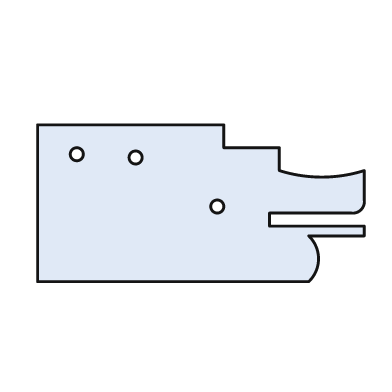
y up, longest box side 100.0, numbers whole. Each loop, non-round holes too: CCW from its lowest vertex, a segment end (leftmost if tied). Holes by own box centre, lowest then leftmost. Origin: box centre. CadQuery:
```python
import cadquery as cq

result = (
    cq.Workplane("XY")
    .moveTo(-50.0, -24.0)
    .lineTo(33.0, -24.0)
    .threePointArc((36.0, -17.0), (33.0, -10.0))
    .lineTo(50.0, -10.0)
    .lineTo(50.0, -7.0)
    .lineTo(21.0, -7.0)
    .lineTo(21.0, -3.0)
    .lineTo(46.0, -3.0)
    .threePointArc((49.0, -2.0), (50.0, 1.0))
    .lineTo(50.0, 10.0)
    .threePointArc((37.0, 8.0), (24.0, 10.0))
    .lineTo(24.0, 17.0)
    .lineTo(7.0, 17.0)
    .lineTo(7.0, 24.0)
    .lineTo(-50.0, 24.0)
    .close()
    .moveTo(5.0, -1.0)
    .circle(2.0)
    .moveTo(-20.0, 14.0)
    .circle(2.0)
    .moveTo(-38.0, 15.0)
    .circle(2.0)
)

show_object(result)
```